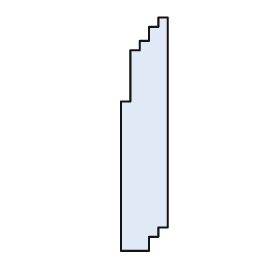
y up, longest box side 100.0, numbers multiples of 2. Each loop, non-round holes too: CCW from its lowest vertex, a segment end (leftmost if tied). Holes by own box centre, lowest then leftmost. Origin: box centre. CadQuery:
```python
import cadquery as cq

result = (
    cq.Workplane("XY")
    .moveTo(-10.0, -50.0)
    .lineTo(2.0, -50.0)
    .lineTo(2.0, -44.0)
    .lineTo(6.0, -44.0)
    .lineTo(6.0, -40.0)
    .lineTo(10.0, -40.0)
    .lineTo(10.0, 50.0)
    .lineTo(6.0, 50.0)
    .lineTo(6.0, 46.0)
    .lineTo(2.0, 46.0)
    .lineTo(2.0, 40.0)
    .lineTo(-2.0, 40.0)
    .lineTo(-2.0, 36.0)
    .lineTo(-6.0, 36.0)
    .lineTo(-6.0, 14.0)
    .lineTo(-10.0, 14.0)
    .close()
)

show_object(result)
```